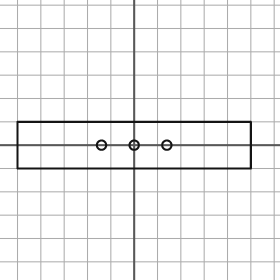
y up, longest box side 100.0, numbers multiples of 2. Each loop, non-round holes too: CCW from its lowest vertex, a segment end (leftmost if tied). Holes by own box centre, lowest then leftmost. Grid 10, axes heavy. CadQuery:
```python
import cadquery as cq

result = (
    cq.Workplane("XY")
    .moveTo(-50.0, -10.0)
    .lineTo(50.0, -10.0)
    .lineTo(50.0, 10.0)
    .lineTo(-50.0, 10.0)
    .close()
    .moveTo(-14.0, 0.0)
    .circle(2.0)
    .moveTo(0.0, 0.0)
    .circle(2.0)
    .moveTo(14.0, 0.0)
    .circle(2.0)
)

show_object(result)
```